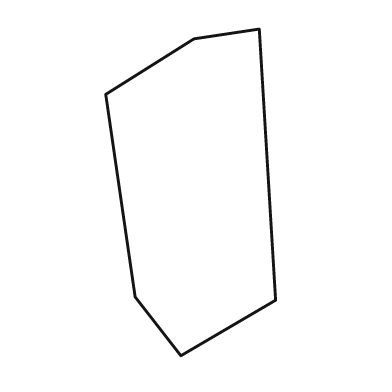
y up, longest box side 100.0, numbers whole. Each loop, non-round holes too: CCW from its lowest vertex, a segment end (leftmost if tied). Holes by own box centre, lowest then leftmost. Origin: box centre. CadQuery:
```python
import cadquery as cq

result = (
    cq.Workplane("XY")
    .moveTo(-3.0, -50.0)
    .lineTo(26.0, -33.0)
    .lineTo(21.0, 50.0)
    .lineTo(1.0, 47.0)
    .lineTo(-26.0, 30.0)
    .lineTo(-17.0, -32.0)
    .close()
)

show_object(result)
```